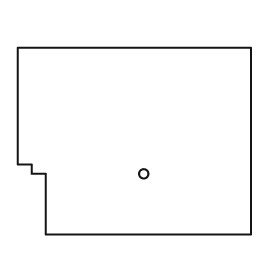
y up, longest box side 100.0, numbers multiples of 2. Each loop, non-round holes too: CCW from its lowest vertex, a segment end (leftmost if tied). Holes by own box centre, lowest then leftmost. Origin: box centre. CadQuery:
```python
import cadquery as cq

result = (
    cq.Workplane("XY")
    .moveTo(-38.0, -40.0)
    .lineTo(50.0, -40.0)
    .lineTo(50.0, 40.0)
    .lineTo(-50.0, 40.0)
    .lineTo(-50.0, -10.0)
    .lineTo(-44.0, -10.0)
    .lineTo(-44.0, -14.0)
    .lineTo(-38.0, -14.0)
    .close()
    .moveTo(4.0, -14.0)
    .circle(2.0)
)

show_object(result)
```